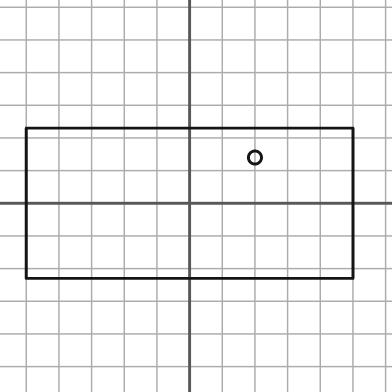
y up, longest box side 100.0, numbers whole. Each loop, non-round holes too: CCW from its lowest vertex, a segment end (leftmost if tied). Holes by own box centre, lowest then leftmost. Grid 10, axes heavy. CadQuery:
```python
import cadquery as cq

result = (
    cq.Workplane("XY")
    .moveTo(-50.0, -23.0)
    .lineTo(50.0, -23.0)
    .lineTo(50.0, 23.0)
    .lineTo(-50.0, 23.0)
    .close()
    .moveTo(20.0, 14.0)
    .circle(2.0)
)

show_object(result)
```